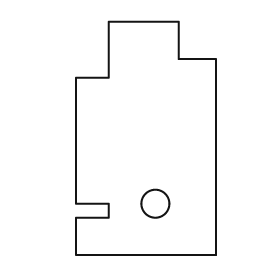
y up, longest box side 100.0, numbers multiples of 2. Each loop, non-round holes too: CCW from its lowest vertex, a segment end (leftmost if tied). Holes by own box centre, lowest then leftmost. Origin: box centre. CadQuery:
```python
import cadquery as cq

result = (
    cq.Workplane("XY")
    .moveTo(-30.0, -50.0)
    .lineTo(30.0, -50.0)
    .lineTo(30.0, 34.0)
    .lineTo(14.0, 34.0)
    .lineTo(14.0, 50.0)
    .lineTo(-16.0, 50.0)
    .lineTo(-16.0, 26.0)
    .lineTo(-30.0, 26.0)
    .lineTo(-30.0, -28.0)
    .lineTo(-16.0, -28.0)
    .lineTo(-16.0, -34.0)
    .lineTo(-30.0, -34.0)
    .close()
    .moveTo(4.0, -28.0)
    .circle(6.0)
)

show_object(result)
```